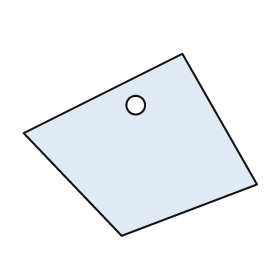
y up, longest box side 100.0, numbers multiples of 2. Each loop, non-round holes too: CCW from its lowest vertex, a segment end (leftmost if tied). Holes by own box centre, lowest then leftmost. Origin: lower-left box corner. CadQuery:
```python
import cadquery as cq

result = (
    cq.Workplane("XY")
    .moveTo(42.0, 0.0)
    .lineTo(100.0, 22.0)
    .lineTo(68.0, 78.0)
    .lineTo(0.0, 44.0)
    .close()
    .moveTo(48.0, 56.0)
    .circle(4.0)
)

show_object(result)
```